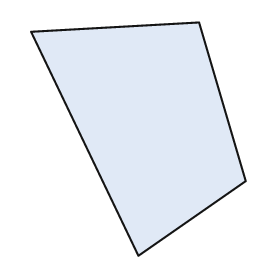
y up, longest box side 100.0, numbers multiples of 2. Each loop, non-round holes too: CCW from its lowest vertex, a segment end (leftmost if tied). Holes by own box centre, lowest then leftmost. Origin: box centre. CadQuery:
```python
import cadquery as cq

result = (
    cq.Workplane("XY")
    .moveTo(0.0, -50.0)
    .lineTo(46.0, -18.0)
    .lineTo(26.0, 50.0)
    .lineTo(-46.0, 46.0)
    .close()
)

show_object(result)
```